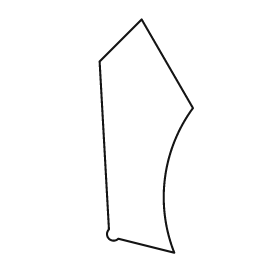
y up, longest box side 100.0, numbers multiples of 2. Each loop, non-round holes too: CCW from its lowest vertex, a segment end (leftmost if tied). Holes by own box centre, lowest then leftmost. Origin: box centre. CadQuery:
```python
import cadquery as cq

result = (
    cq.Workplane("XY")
    .moveTo(12.0, -50.0)
    .threePointArc((8.0, -18.0), (20.0, 12.0))
    .lineTo(-2.0, 50.0)
    .lineTo(-20.0, 32.0)
    .lineTo(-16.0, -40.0)
    .threePointArc((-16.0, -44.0), (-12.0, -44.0))
    .close()
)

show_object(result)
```